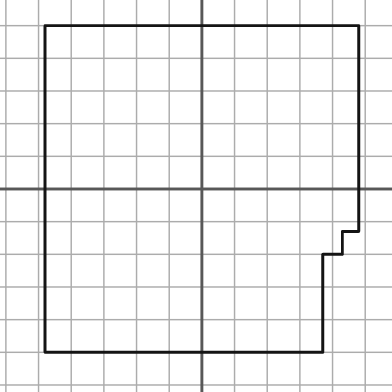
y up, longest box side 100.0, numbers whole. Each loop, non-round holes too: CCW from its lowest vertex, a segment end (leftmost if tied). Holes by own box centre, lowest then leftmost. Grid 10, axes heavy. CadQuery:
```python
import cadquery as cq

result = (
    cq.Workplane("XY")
    .moveTo(-48.0, -50.0)
    .lineTo(37.0, -50.0)
    .lineTo(37.0, -20.0)
    .lineTo(43.0, -20.0)
    .lineTo(43.0, -13.0)
    .lineTo(48.0, -13.0)
    .lineTo(48.0, 50.0)
    .lineTo(-48.0, 50.0)
    .close()
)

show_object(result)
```